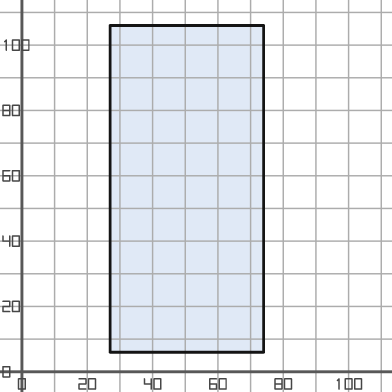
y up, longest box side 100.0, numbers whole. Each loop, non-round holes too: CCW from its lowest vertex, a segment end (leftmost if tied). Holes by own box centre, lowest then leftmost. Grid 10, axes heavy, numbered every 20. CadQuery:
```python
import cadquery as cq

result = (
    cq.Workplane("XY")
    .moveTo(27.0, 6.0)
    .lineTo(74.0, 6.0)
    .lineTo(74.0, 106.0)
    .lineTo(27.0, 106.0)
    .close()
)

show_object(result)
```